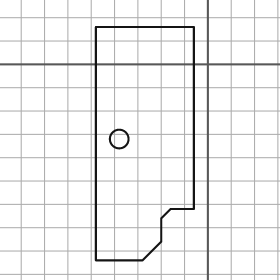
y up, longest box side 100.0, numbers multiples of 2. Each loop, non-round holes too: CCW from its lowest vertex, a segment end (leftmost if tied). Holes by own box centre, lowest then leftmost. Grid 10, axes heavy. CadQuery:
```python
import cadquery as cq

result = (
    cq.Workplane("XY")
    .moveTo(-48.0, -84.0)
    .lineTo(-28.0, -84.0)
    .lineTo(-20.0, -76.0)
    .lineTo(-20.0, -66.0)
    .lineTo(-16.0, -62.0)
    .lineTo(-6.0, -62.0)
    .lineTo(-6.0, 16.0)
    .lineTo(-48.0, 16.0)
    .close()
    .moveTo(-38.0, -32.0)
    .circle(4.0)
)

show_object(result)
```